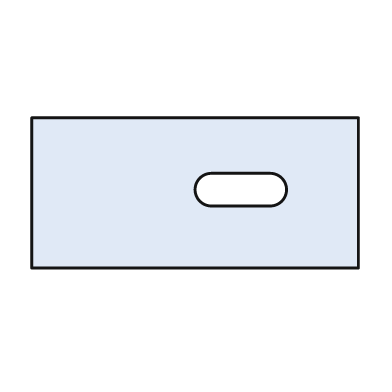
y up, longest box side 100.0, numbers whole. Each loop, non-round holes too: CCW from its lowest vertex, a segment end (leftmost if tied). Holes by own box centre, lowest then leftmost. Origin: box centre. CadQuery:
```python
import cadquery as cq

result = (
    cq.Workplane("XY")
    .moveTo(-50.0, -23.0)
    .lineTo(50.0, -23.0)
    .lineTo(50.0, 23.0)
    .lineTo(-50.0, 23.0)
    .close()
    .moveTo(5.0, -4.0)
    .lineTo(23.0, -4.0)
    .threePointArc((28.0, 1.0), (23.0, 6.0))
    .lineTo(5.0, 6.0)
    .threePointArc((0.0, 1.0), (5.0, -4.0))
    .close()
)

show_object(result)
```